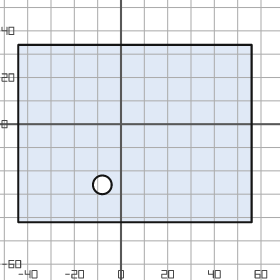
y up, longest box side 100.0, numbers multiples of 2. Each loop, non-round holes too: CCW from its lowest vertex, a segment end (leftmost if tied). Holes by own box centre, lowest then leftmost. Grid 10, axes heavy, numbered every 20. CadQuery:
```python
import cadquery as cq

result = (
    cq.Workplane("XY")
    .moveTo(-44.0, -42.0)
    .lineTo(56.0, -42.0)
    .lineTo(56.0, 34.0)
    .lineTo(-44.0, 34.0)
    .close()
    .moveTo(-8.0, -26.0)
    .circle(4.0)
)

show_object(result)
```